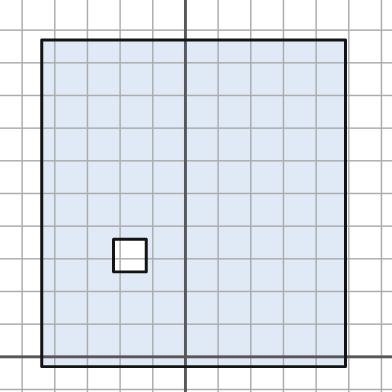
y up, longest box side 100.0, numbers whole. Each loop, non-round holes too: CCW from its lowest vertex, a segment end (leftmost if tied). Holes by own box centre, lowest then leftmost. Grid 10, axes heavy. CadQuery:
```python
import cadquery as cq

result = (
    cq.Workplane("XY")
    .moveTo(-44.0, -3.0)
    .lineTo(49.0, -3.0)
    .lineTo(49.0, 97.0)
    .lineTo(-44.0, 97.0)
    .close()
    .moveTo(-22.0, 26.0)
    .lineTo(-12.0, 26.0)
    .lineTo(-12.0, 36.0)
    .lineTo(-22.0, 36.0)
    .close()
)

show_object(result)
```